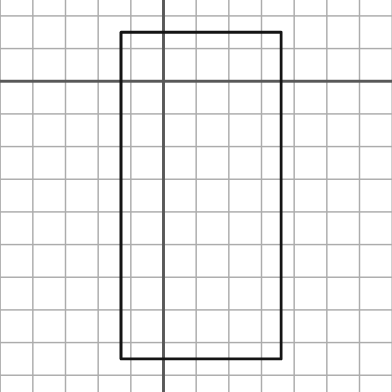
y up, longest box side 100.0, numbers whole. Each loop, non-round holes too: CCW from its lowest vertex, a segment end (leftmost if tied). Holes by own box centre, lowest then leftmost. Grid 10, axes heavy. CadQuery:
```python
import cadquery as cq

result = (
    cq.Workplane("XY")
    .moveTo(-13.0, -85.0)
    .lineTo(36.0, -85.0)
    .lineTo(36.0, 15.0)
    .lineTo(-13.0, 15.0)
    .close()
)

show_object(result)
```